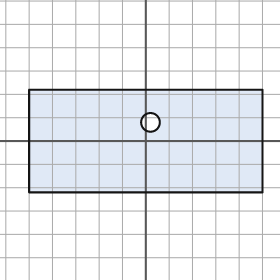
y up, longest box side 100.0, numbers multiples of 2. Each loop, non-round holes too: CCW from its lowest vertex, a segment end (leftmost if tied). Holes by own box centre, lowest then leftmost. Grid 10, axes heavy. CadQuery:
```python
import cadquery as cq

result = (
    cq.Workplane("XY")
    .moveTo(-50.0, -22.0)
    .lineTo(50.0, -22.0)
    .lineTo(50.0, 22.0)
    .lineTo(-50.0, 22.0)
    .close()
    .moveTo(2.0, 8.0)
    .circle(4.0)
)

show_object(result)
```